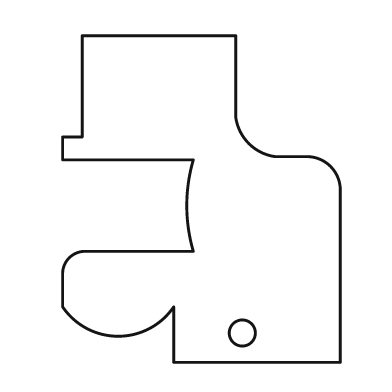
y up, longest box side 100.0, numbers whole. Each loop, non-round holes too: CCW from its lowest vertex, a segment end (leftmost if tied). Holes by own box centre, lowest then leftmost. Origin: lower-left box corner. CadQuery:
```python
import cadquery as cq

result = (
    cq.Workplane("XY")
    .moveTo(34.0, 0.0)
    .lineTo(85.0, 0.0)
    .lineTo(85.0, 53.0)
    .threePointArc((82.0, 60.0), (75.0, 63.0))
    .lineTo(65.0, 63.0)
    .threePointArc((57.0, 67.0), (53.0, 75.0))
    .lineTo(53.0, 100.0)
    .lineTo(6.0, 100.0)
    .lineTo(6.0, 69.0)
    .lineTo(0.0, 69.0)
    .lineTo(0.0, 62.0)
    .lineTo(40.0, 62.0)
    .threePointArc((38.0, 48.0), (40.0, 34.0))
    .lineTo(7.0, 34.0)
    .threePointArc((2.0, 32.0), (0.0, 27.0))
    .lineTo(0.0, 17.0)
    .threePointArc((17.0, 8.0), (34.0, 17.0))
    .close()
    .moveTo(55.0, 9.0)
    .circle(4.0)
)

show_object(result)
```